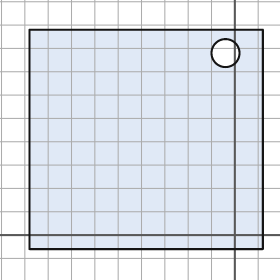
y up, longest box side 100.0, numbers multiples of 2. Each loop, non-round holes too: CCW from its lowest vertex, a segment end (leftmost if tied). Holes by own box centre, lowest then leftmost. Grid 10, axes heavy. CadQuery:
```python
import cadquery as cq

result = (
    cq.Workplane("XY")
    .moveTo(-88.0, -6.0)
    .lineTo(12.0, -6.0)
    .lineTo(12.0, 88.0)
    .lineTo(-88.0, 88.0)
    .close()
    .moveTo(-4.0, 78.0)
    .circle(6.0)
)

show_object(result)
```